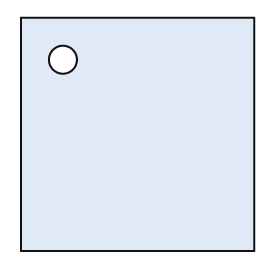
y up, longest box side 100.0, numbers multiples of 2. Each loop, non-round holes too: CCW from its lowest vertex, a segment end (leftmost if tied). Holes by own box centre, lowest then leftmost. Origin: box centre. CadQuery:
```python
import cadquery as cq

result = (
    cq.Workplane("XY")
    .moveTo(-50.0, -50.0)
    .lineTo(50.0, -50.0)
    .lineTo(50.0, 50.0)
    .lineTo(-50.0, 50.0)
    .close()
    .moveTo(-32.0, 32.0)
    .circle(6.0)
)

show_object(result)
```